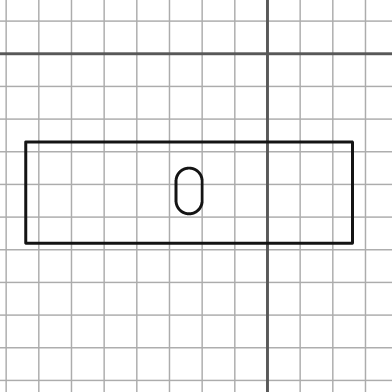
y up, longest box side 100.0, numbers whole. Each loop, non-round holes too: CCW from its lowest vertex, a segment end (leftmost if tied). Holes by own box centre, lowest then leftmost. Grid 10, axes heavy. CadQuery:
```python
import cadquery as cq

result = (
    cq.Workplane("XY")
    .moveTo(-74.0, -58.0)
    .lineTo(26.0, -58.0)
    .lineTo(26.0, -27.0)
    .lineTo(-74.0, -27.0)
    .close()
    .moveTo(-28.0, -45.0)
    .threePointArc((-24.0, -49.0), (-20.0, -45.0))
    .lineTo(-20.0, -39.0)
    .threePointArc((-24.0, -35.0), (-28.0, -39.0))
    .close()
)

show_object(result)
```